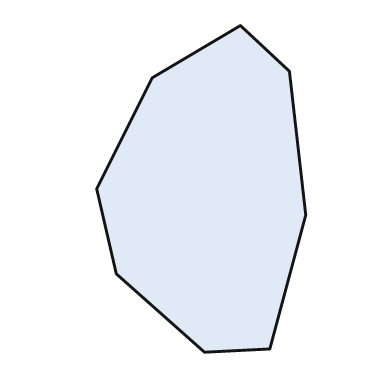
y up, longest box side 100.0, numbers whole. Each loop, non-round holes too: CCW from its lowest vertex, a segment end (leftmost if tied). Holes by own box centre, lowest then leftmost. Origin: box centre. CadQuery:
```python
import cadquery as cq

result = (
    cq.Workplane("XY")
    .moveTo(1.0, -50.0)
    .lineTo(21.0, -49.0)
    .lineTo(32.0, -8.0)
    .lineTo(27.0, 36.0)
    .lineTo(12.0, 50.0)
    .lineTo(-15.0, 34.0)
    .lineTo(-32.0, 0.0)
    .lineTo(-26.0, -26.0)
    .close()
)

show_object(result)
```